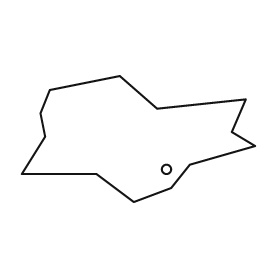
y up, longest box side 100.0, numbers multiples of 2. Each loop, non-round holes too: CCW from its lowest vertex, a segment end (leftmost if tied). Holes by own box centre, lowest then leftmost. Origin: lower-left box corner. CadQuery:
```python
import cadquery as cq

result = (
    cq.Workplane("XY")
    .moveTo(48.0, 0.0)
    .lineTo(64.0, 6.0)
    .lineTo(72.0, 16.0)
    .lineTo(100.0, 24.0)
    .lineTo(90.0, 30.0)
    .lineTo(96.0, 44.0)
    .lineTo(58.0, 40.0)
    .lineTo(42.0, 54.0)
    .lineTo(12.0, 48.0)
    .lineTo(8.0, 38.0)
    .lineTo(10.0, 28.0)
    .lineTo(0.0, 12.0)
    .lineTo(32.0, 12.0)
    .close()
    .moveTo(62.0, 14.0)
    .circle(2.0)
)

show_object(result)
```